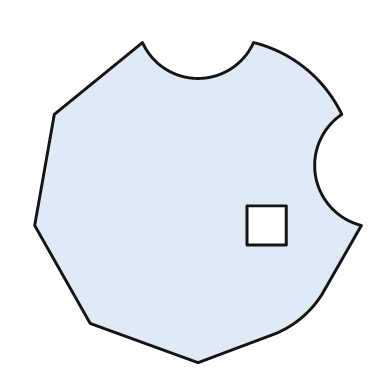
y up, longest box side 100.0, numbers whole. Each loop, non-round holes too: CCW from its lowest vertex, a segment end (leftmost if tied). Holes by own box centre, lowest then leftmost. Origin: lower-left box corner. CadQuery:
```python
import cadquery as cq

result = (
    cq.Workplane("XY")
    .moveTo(50.0, 0.0)
    .lineTo(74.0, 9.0)
    .threePointArc((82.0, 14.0), (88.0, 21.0))
    .lineTo(100.0, 42.0)
    .threePointArc((86.0, 57.0), (94.0, 76.0))
    .threePointArc((83.0, 90.0), (67.0, 98.0))
    .threePointArc((50.0, 87.0), (33.0, 98.0))
    .lineTo(6.0, 76.0)
    .lineTo(0.0, 42.0)
    .lineTo(17.0, 12.0)
    .close()
    .moveTo(65.0, 36.0)
    .lineTo(77.0, 36.0)
    .lineTo(77.0, 48.0)
    .lineTo(65.0, 48.0)
    .close()
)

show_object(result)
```